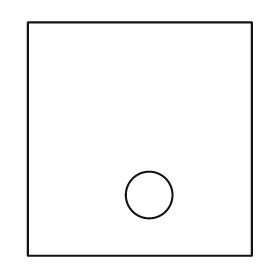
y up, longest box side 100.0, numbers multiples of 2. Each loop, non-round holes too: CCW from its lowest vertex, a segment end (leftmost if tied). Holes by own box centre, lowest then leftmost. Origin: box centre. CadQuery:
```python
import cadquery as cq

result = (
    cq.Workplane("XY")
    .moveTo(-48.0, -50.0)
    .lineTo(48.0, -50.0)
    .lineTo(48.0, 50.0)
    .lineTo(-48.0, 50.0)
    .close()
    .moveTo(4.0, -24.0)
    .circle(10.0)
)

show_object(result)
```